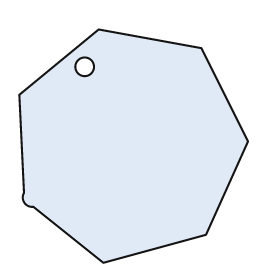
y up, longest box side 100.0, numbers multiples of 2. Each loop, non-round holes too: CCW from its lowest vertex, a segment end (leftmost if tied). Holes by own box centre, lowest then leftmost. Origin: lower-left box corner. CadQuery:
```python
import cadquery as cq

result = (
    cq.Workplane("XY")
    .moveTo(36.0, 0.0)
    .lineTo(80.0, 12.0)
    .lineTo(98.0, 52.0)
    .lineTo(78.0, 92.0)
    .lineTo(34.0, 100.0)
    .lineTo(0.0, 72.0)
    .lineTo(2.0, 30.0)
    .threePointArc((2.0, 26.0), (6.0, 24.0))
    .close()
    .moveTo(28.0, 84.0)
    .circle(4.0)
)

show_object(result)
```